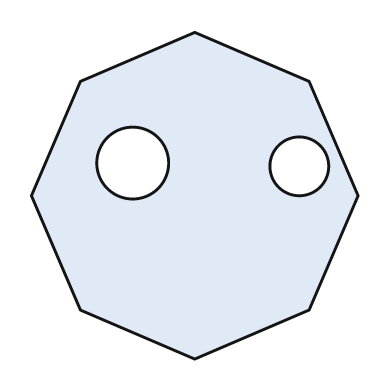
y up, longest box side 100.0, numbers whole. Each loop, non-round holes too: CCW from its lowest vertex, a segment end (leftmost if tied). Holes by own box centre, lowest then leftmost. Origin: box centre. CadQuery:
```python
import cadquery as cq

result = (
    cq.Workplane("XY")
    .moveTo(0.0, -50.0)
    .lineTo(35.0, -35.0)
    .lineTo(50.0, 0.0)
    .lineTo(35.0, 35.0)
    .lineTo(0.0, 50.0)
    .lineTo(-35.0, 35.0)
    .lineTo(-50.0, 0.0)
    .lineTo(-35.0, -35.0)
    .close()
    .moveTo(32.0, 9.0)
    .circle(9.0)
    .moveTo(-19.0, 10.0)
    .circle(11.0)
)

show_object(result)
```